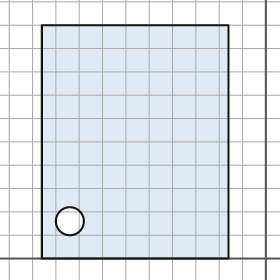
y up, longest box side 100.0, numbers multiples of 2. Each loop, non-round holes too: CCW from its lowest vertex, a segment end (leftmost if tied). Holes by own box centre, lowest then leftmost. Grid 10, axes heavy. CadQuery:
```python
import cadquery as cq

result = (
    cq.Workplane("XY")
    .moveTo(-96.0, 0.0)
    .lineTo(-16.0, 0.0)
    .lineTo(-16.0, 100.0)
    .lineTo(-96.0, 100.0)
    .close()
    .moveTo(-84.0, 16.0)
    .circle(6.0)
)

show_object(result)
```